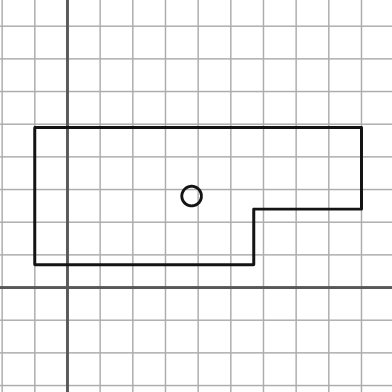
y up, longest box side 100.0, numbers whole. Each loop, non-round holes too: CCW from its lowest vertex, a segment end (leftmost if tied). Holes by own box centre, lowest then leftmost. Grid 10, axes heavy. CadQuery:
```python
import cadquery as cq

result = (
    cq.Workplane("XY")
    .moveTo(-10.0, 7.0)
    .lineTo(57.0, 7.0)
    .lineTo(57.0, 24.0)
    .lineTo(90.0, 24.0)
    .lineTo(90.0, 49.0)
    .lineTo(-10.0, 49.0)
    .close()
    .moveTo(38.0, 28.0)
    .circle(3.0)
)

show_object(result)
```